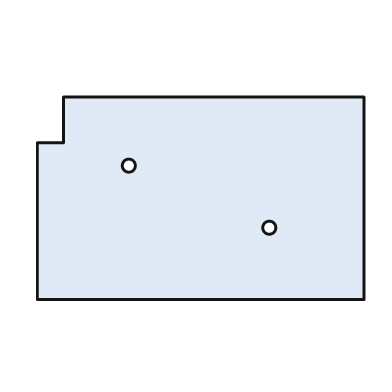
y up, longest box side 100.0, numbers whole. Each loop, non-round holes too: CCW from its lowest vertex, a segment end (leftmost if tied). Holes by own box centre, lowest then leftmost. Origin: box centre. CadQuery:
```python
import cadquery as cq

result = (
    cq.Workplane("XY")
    .moveTo(-50.0, -31.0)
    .lineTo(50.0, -31.0)
    .lineTo(50.0, 31.0)
    .lineTo(-42.0, 31.0)
    .lineTo(-42.0, 17.0)
    .lineTo(-50.0, 17.0)
    .close()
    .moveTo(21.0, -9.0)
    .circle(2.0)
    .moveTo(-22.0, 10.0)
    .circle(2.0)
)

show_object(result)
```